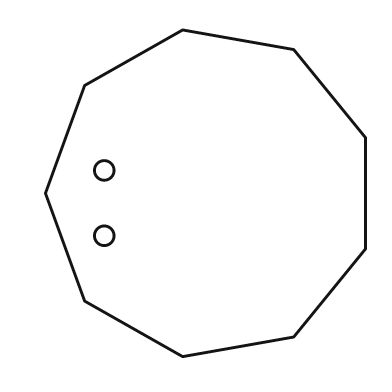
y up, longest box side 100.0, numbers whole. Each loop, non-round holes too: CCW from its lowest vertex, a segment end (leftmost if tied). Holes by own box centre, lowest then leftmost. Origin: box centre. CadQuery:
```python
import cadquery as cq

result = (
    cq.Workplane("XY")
    .moveTo(-7.0, -50.0)
    .lineTo(27.0, -44.0)
    .lineTo(49.0, -17.0)
    .lineTo(49.0, 17.0)
    .lineTo(27.0, 44.0)
    .lineTo(-7.0, 50.0)
    .lineTo(-37.0, 33.0)
    .lineTo(-49.0, 0.0)
    .lineTo(-37.0, -33.0)
    .close()
    .moveTo(-31.0, -13.0)
    .circle(3.0)
    .moveTo(-31.0, 7.0)
    .circle(3.0)
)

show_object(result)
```